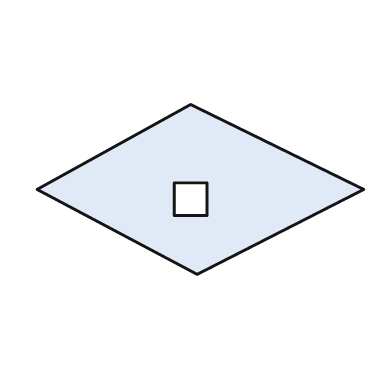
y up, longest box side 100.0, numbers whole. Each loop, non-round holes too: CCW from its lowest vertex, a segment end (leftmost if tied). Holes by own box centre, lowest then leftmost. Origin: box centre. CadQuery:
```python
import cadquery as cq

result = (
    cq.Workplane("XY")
    .moveTo(-1.0, -26.0)
    .lineTo(50.0, 0.0)
    .lineTo(-3.0, 26.0)
    .lineTo(-50.0, 0.0)
    .close()
    .moveTo(-8.0, -8.0)
    .lineTo(2.0, -8.0)
    .lineTo(2.0, 2.0)
    .lineTo(-8.0, 2.0)
    .close()
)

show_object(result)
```